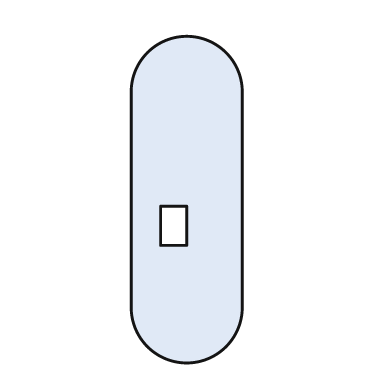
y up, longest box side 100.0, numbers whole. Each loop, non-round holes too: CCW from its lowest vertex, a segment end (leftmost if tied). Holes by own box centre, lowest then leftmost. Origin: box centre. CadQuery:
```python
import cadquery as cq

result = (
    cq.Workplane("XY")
    .moveTo(-17.0, -33.0)
    .threePointArc((0.0, -50.0), (17.0, -33.0))
    .lineTo(17.0, 33.0)
    .threePointArc((0.0, 50.0), (-17.0, 33.0))
    .close()
    .moveTo(-8.0, -14.0)
    .lineTo(0.0, -14.0)
    .lineTo(0.0, -2.0)
    .lineTo(-8.0, -2.0)
    .close()
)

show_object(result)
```